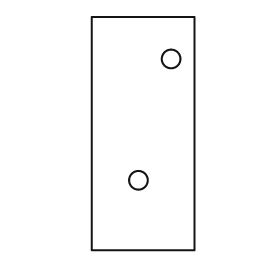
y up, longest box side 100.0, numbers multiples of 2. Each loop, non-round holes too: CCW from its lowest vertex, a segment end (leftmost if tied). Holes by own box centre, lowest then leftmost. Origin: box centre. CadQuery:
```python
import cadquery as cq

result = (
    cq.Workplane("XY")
    .moveTo(-22.0, -50.0)
    .lineTo(22.0, -50.0)
    .lineTo(22.0, 50.0)
    .lineTo(-22.0, 50.0)
    .close()
    .moveTo(-2.0, -20.0)
    .circle(4.0)
    .moveTo(12.0, 32.0)
    .circle(4.0)
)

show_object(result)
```